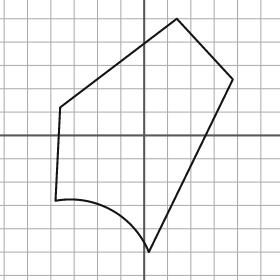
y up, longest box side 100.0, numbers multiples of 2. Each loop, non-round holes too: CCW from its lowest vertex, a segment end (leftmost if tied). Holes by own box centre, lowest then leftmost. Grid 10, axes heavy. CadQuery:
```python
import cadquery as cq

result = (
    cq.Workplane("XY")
    .moveTo(2.0, -50.0)
    .lineTo(38.0, 24.0)
    .lineTo(14.0, 50.0)
    .lineTo(-36.0, 12.0)
    .lineTo(-38.0, -28.0)
    .threePointArc((-14.0, -32.0), (2.0, -50.0))
    .close()
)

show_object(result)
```